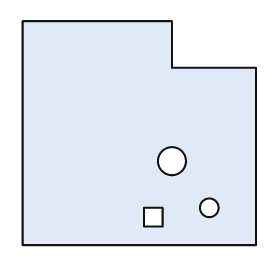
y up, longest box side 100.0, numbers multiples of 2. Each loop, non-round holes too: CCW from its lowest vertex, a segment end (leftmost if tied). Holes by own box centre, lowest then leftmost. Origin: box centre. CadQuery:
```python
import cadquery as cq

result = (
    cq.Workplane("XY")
    .moveTo(-50.0, -48.0)
    .lineTo(50.0, -48.0)
    .lineTo(50.0, 28.0)
    .lineTo(14.0, 28.0)
    .lineTo(14.0, 48.0)
    .lineTo(-50.0, 48.0)
    .close()
    .moveTo(2.0, -40.0)
    .lineTo(10.0, -40.0)
    .lineTo(10.0, -32.0)
    .lineTo(2.0, -32.0)
    .close()
    .moveTo(30.0, -32.0)
    .circle(4.0)
    .moveTo(14.0, -12.0)
    .circle(6.0)
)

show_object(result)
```